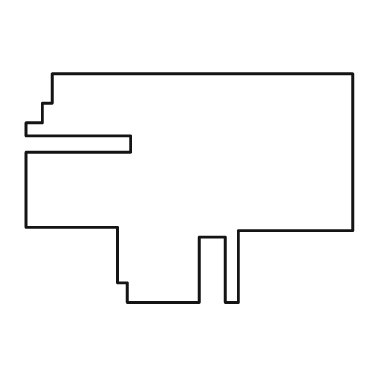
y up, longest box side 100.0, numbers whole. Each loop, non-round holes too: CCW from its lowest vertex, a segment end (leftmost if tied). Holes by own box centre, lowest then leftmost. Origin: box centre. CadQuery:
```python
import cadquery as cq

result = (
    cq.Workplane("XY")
    .moveTo(-19.0, -35.0)
    .lineTo(3.0, -35.0)
    .lineTo(3.0, -15.0)
    .lineTo(11.0, -15.0)
    .lineTo(11.0, -35.0)
    .lineTo(15.0, -35.0)
    .lineTo(15.0, -13.0)
    .lineTo(50.0, -13.0)
    .lineTo(50.0, 35.0)
    .lineTo(-42.0, 35.0)
    .lineTo(-42.0, 26.0)
    .lineTo(-45.0, 26.0)
    .lineTo(-45.0, 20.0)
    .lineTo(-50.0, 20.0)
    .lineTo(-50.0, 16.0)
    .lineTo(-18.0, 16.0)
    .lineTo(-18.0, 11.0)
    .lineTo(-50.0, 11.0)
    .lineTo(-50.0, -12.0)
    .lineTo(-22.0, -12.0)
    .lineTo(-22.0, -29.0)
    .lineTo(-19.0, -29.0)
    .close()
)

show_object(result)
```